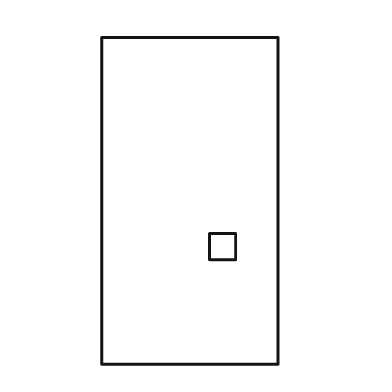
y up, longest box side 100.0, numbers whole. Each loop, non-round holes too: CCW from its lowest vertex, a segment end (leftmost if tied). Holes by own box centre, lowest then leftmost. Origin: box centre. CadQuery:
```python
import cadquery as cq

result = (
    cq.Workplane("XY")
    .moveTo(-27.0, -50.0)
    .lineTo(27.0, -50.0)
    .lineTo(27.0, 50.0)
    .lineTo(-27.0, 50.0)
    .close()
    .moveTo(6.0, -18.0)
    .lineTo(14.0, -18.0)
    .lineTo(14.0, -10.0)
    .lineTo(6.0, -10.0)
    .close()
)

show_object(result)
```